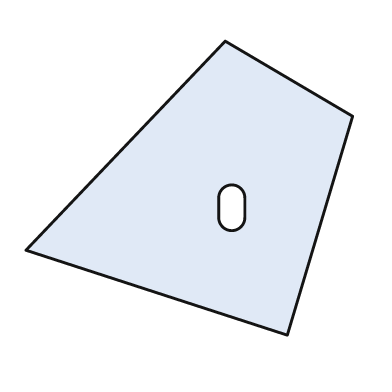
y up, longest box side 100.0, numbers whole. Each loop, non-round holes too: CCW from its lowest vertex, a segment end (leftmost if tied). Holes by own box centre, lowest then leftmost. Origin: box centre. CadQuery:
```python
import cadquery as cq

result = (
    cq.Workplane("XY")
    .moveTo(30.0, -45.0)
    .lineTo(50.0, 22.0)
    .lineTo(11.0, 45.0)
    .lineTo(-50.0, -19.0)
    .close()
    .moveTo(9.0, -9.0)
    .threePointArc((13.0, -13.0), (17.0, -9.0))
    .lineTo(17.0, -3.0)
    .threePointArc((13.0, 1.0), (9.0, -3.0))
    .close()
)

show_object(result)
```